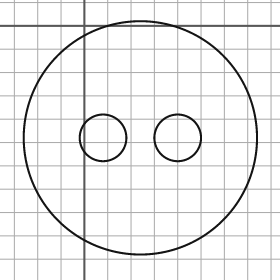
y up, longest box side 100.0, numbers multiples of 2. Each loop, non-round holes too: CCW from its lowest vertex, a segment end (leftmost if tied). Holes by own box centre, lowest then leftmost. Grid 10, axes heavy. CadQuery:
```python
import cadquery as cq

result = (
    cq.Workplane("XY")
    .moveTo(24.0, -48.0)
    .circle(50.0)
    .moveTo(8.0, -48.0)
    .circle(10.0)
    .moveTo(40.0, -48.0)
    .circle(10.0)
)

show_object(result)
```